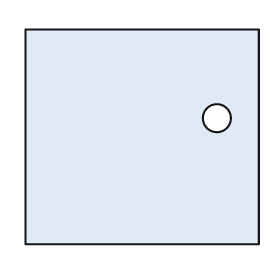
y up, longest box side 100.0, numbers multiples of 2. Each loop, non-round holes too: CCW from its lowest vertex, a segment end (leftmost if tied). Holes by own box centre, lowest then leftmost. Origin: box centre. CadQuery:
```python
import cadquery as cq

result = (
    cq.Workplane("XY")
    .moveTo(-50.0, -46.0)
    .lineTo(50.0, -46.0)
    .lineTo(50.0, 46.0)
    .lineTo(-50.0, 46.0)
    .close()
    .moveTo(32.0, 8.0)
    .circle(6.0)
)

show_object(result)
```